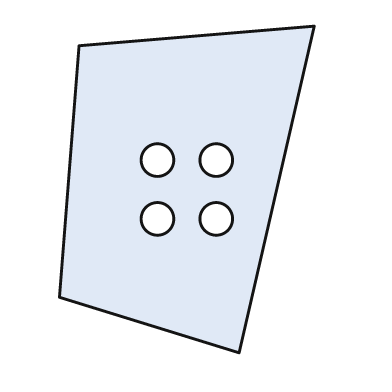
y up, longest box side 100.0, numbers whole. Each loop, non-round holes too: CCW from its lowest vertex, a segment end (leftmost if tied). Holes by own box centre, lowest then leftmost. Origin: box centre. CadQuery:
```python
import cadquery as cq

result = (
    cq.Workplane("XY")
    .moveTo(16.0, -50.0)
    .lineTo(39.0, 50.0)
    .lineTo(-33.0, 44.0)
    .lineTo(-39.0, -33.0)
    .close()
    .moveTo(-9.0, -9.0)
    .circle(5.0)
    .moveTo(9.0, -9.0)
    .circle(5.0)
    .moveTo(-9.0, 9.0)
    .circle(5.0)
    .moveTo(9.0, 9.0)
    .circle(5.0)
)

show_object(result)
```